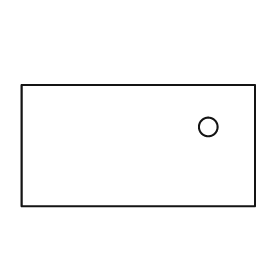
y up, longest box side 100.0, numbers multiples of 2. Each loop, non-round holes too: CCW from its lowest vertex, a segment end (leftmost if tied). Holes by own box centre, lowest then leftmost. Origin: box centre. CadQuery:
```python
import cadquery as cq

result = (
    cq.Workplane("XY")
    .moveTo(-50.0, -26.0)
    .lineTo(50.0, -26.0)
    .lineTo(50.0, 26.0)
    .lineTo(-50.0, 26.0)
    .close()
    .moveTo(30.0, 8.0)
    .circle(4.0)
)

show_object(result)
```